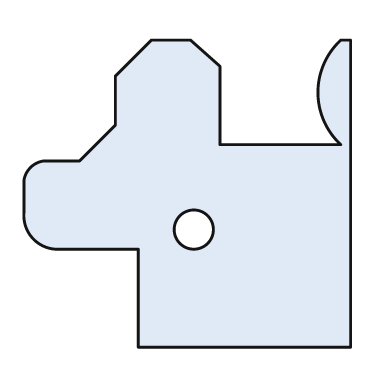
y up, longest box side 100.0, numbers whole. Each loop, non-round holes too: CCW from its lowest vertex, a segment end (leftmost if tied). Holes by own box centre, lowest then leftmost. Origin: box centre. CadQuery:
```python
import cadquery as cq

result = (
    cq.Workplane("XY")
    .moveTo(-15.0, -47.0)
    .lineTo(50.0, -47.0)
    .lineTo(50.0, 47.0)
    .lineTo(47.0, 47.0)
    .threePointArc((40.0, 31.0), (47.0, 15.0))
    .lineTo(10.0, 15.0)
    .lineTo(10.0, 39.0)
    .lineTo(1.0, 47.0)
    .lineTo(-11.0, 47.0)
    .lineTo(-22.0, 36.0)
    .lineTo(-22.0, 21.0)
    .lineTo(-33.0, 10.0)
    .lineTo(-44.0, 10.0)
    .threePointArc((-48.0, 8.0), (-50.0, 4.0))
    .lineTo(-50.0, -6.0)
    .threePointArc((-47.0, -14.0), (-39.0, -17.0))
    .lineTo(-15.0, -17.0)
    .close()
    .moveTo(2.0, -11.0)
    .circle(6.0)
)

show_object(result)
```